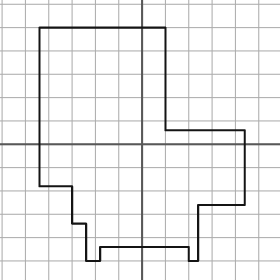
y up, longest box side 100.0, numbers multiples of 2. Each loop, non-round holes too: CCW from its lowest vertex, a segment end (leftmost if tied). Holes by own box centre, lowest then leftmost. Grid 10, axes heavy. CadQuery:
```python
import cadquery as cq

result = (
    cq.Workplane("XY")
    .moveTo(-24.0, -50.0)
    .lineTo(-18.0, -50.0)
    .lineTo(-18.0, -44.0)
    .lineTo(20.0, -44.0)
    .lineTo(20.0, -50.0)
    .lineTo(24.0, -50.0)
    .lineTo(24.0, -26.0)
    .lineTo(44.0, -26.0)
    .lineTo(44.0, 6.0)
    .lineTo(10.0, 6.0)
    .lineTo(10.0, 50.0)
    .lineTo(-44.0, 50.0)
    .lineTo(-44.0, -18.0)
    .lineTo(-30.0, -18.0)
    .lineTo(-30.0, -34.0)
    .lineTo(-24.0, -34.0)
    .close()
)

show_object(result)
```